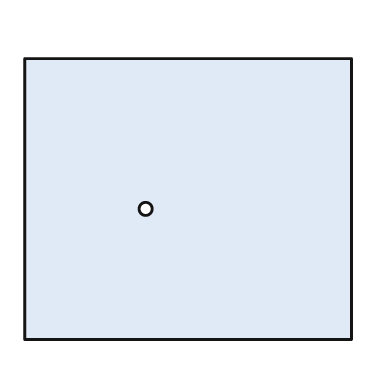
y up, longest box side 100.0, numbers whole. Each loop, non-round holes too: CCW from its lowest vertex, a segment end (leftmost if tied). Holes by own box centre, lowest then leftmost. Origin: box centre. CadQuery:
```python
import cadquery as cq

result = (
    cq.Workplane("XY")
    .moveTo(-50.0, -43.0)
    .lineTo(50.0, -43.0)
    .lineTo(50.0, 43.0)
    .lineTo(-50.0, 43.0)
    .close()
    .moveTo(-13.0, -3.0)
    .circle(2.0)
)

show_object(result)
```